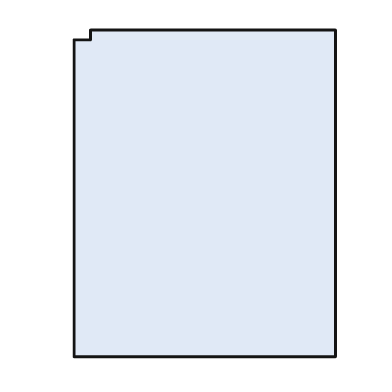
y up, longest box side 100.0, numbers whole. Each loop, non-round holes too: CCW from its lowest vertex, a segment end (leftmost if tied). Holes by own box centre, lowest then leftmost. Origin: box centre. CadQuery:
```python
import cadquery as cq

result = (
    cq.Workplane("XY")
    .moveTo(-40.0, -50.0)
    .lineTo(40.0, -50.0)
    .lineTo(40.0, 50.0)
    .lineTo(-35.0, 50.0)
    .lineTo(-35.0, 47.0)
    .lineTo(-40.0, 47.0)
    .close()
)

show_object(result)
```